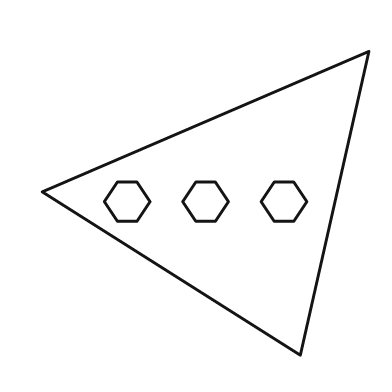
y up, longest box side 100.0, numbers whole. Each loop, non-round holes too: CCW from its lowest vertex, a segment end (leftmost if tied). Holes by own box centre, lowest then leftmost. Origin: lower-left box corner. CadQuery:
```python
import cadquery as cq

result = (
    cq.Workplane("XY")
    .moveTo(79.0, 0.0)
    .lineTo(100.0, 93.0)
    .lineTo(0.0, 50.0)
    .close()
    .moveTo(23.0, 41.0)
    .lineTo(29.0, 41.0)
    .lineTo(33.0, 47.0)
    .lineTo(29.0, 53.0)
    .lineTo(23.0, 53.0)
    .lineTo(19.0, 47.0)
    .close()
    .moveTo(47.0, 41.0)
    .lineTo(53.0, 41.0)
    .lineTo(57.0, 47.0)
    .lineTo(53.0, 53.0)
    .lineTo(47.0, 53.0)
    .lineTo(43.0, 47.0)
    .close()
    .moveTo(71.0, 41.0)
    .lineTo(77.0, 41.0)
    .lineTo(81.0, 47.0)
    .lineTo(77.0, 53.0)
    .lineTo(71.0, 53.0)
    .lineTo(67.0, 47.0)
    .close()
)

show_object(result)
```